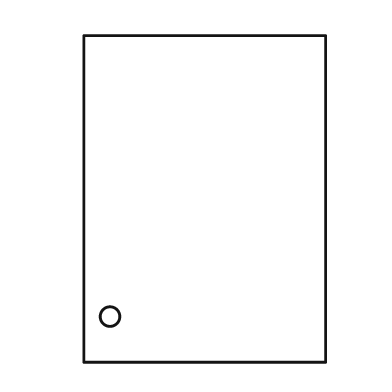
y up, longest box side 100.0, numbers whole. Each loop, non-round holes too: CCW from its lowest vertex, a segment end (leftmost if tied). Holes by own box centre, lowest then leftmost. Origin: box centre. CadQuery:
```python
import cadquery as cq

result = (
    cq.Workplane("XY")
    .moveTo(-37.0, -50.0)
    .lineTo(37.0, -50.0)
    .lineTo(37.0, 50.0)
    .lineTo(-37.0, 50.0)
    .close()
    .moveTo(-29.0, -36.0)
    .circle(3.0)
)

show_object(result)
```